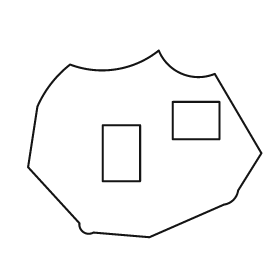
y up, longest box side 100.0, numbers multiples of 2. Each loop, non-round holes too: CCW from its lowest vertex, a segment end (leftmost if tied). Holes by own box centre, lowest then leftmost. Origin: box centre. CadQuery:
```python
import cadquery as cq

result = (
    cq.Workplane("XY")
    .moveTo(2.0, -40.0)
    .lineTo(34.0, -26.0)
    .threePointArc((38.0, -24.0), (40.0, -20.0))
    .lineTo(50.0, -4.0)
    .lineTo(30.0, 30.0)
    .threePointArc((16.0, 30.0), (6.0, 40.0))
    .threePointArc((-12.0, 32.0), (-32.0, 34.0))
    .threePointArc((-40.0, 26.0), (-46.0, 16.0))
    .lineTo(-50.0, -10.0)
    .lineTo(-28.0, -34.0)
    .threePointArc((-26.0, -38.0), (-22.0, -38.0))
    .close()
    .moveTo(-18.0, -16.0)
    .lineTo(-2.0, -16.0)
    .lineTo(-2.0, 8.0)
    .lineTo(-18.0, 8.0)
    .close()
    .moveTo(12.0, 2.0)
    .lineTo(32.0, 2.0)
    .lineTo(32.0, 18.0)
    .lineTo(12.0, 18.0)
    .close()
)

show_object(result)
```